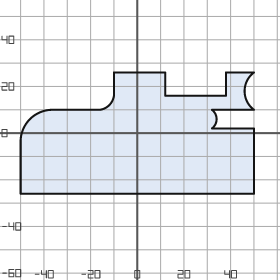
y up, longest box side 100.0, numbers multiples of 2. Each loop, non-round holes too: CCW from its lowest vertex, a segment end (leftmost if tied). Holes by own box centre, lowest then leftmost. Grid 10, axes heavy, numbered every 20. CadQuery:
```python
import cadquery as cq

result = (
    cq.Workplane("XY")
    .moveTo(-50.0, -26.0)
    .lineTo(50.0, -26.0)
    .lineTo(50.0, 2.0)
    .lineTo(32.0, 2.0)
    .threePointArc((34.0, 6.0), (32.0, 10.0))
    .lineTo(50.0, 10.0)
    .threePointArc((46.0, 18.0), (50.0, 26.0))
    .lineTo(38.0, 26.0)
    .lineTo(38.0, 16.0)
    .lineTo(12.0, 16.0)
    .lineTo(12.0, 26.0)
    .lineTo(-10.0, 26.0)
    .lineTo(-10.0, 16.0)
    .threePointArc((-12.0, 12.0), (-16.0, 10.0))
    .lineTo(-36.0, 10.0)
    .threePointArc((-46.0, 6.0), (-50.0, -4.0))
    .close()
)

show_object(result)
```